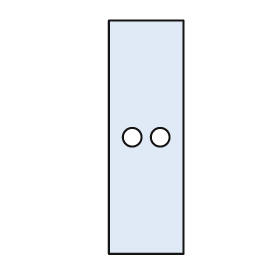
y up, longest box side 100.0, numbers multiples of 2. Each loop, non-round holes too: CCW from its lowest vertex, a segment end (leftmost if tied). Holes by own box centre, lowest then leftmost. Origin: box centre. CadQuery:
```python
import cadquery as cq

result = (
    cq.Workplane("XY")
    .moveTo(-16.0, -50.0)
    .lineTo(16.0, -50.0)
    .lineTo(16.0, 50.0)
    .lineTo(-16.0, 50.0)
    .close()
    .moveTo(-6.0, 0.0)
    .circle(4.0)
    .moveTo(6.0, 0.0)
    .circle(4.0)
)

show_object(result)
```